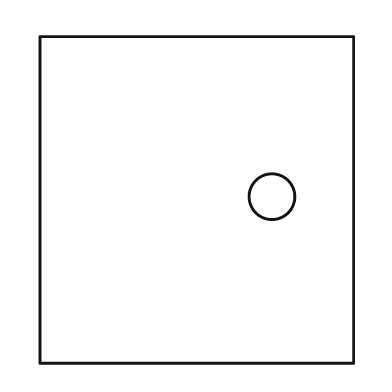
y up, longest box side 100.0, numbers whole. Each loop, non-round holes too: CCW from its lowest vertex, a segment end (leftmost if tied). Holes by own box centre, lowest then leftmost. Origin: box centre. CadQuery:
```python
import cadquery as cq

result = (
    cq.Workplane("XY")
    .moveTo(-48.0, -50.0)
    .lineTo(48.0, -50.0)
    .lineTo(48.0, 50.0)
    .lineTo(-48.0, 50.0)
    .close()
    .moveTo(23.0, 1.0)
    .circle(7.0)
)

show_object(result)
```